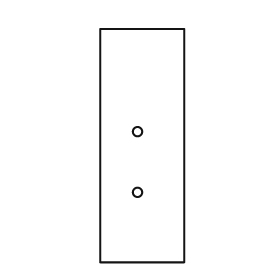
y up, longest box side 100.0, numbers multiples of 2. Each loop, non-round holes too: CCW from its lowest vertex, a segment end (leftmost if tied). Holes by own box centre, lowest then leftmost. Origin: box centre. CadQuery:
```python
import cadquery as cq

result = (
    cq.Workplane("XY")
    .moveTo(-18.0, -50.0)
    .lineTo(18.0, -50.0)
    .lineTo(18.0, 50.0)
    .lineTo(-18.0, 50.0)
    .close()
    .moveTo(-2.0, -20.0)
    .circle(2.0)
    .moveTo(-2.0, 6.0)
    .circle(2.0)
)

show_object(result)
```